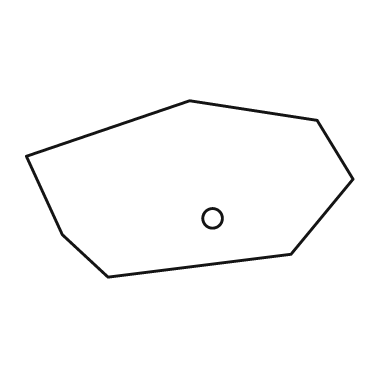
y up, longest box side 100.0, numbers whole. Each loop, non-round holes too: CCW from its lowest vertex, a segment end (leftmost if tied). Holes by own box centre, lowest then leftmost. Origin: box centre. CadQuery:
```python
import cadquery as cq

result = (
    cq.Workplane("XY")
    .moveTo(-25.0, -27.0)
    .lineTo(31.0, -20.0)
    .lineTo(50.0, 3.0)
    .lineTo(39.0, 21.0)
    .lineTo(0.0, 27.0)
    .lineTo(-50.0, 10.0)
    .lineTo(-39.0, -14.0)
    .close()
    .moveTo(7.0, -9.0)
    .circle(3.0)
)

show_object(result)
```